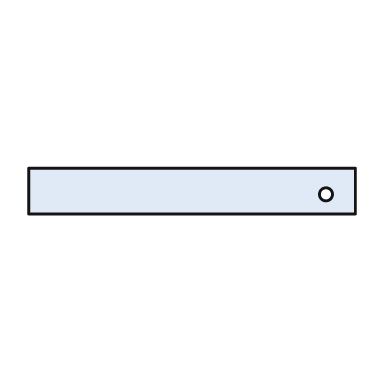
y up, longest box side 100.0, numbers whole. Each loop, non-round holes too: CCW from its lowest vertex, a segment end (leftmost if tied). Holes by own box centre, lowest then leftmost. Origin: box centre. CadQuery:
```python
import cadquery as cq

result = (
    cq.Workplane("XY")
    .moveTo(-50.0, -7.0)
    .lineTo(50.0, -7.0)
    .lineTo(50.0, 7.0)
    .lineTo(-50.0, 7.0)
    .close()
    .moveTo(41.0, -1.0)
    .circle(2.0)
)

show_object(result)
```